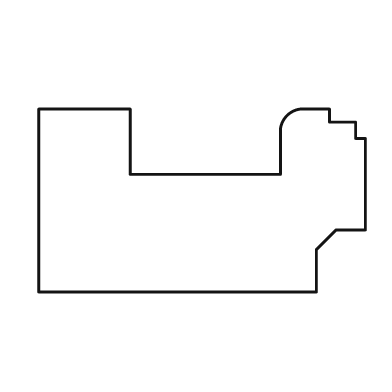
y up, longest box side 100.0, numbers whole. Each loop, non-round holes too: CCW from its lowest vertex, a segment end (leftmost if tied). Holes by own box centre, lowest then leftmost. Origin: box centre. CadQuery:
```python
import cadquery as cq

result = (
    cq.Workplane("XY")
    .moveTo(-50.0, -28.0)
    .lineTo(35.0, -28.0)
    .lineTo(35.0, -15.0)
    .lineTo(41.0, -9.0)
    .lineTo(50.0, -9.0)
    .lineTo(50.0, 19.0)
    .lineTo(47.0, 19.0)
    .lineTo(47.0, 24.0)
    .lineTo(39.0, 24.0)
    .lineTo(39.0, 28.0)
    .lineTo(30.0, 28.0)
    .threePointArc((26.0, 26.0), (24.0, 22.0))
    .lineTo(24.0, 8.0)
    .lineTo(-22.0, 8.0)
    .lineTo(-22.0, 28.0)
    .lineTo(-50.0, 28.0)
    .close()
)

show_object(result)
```